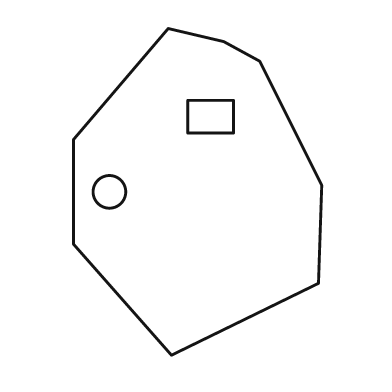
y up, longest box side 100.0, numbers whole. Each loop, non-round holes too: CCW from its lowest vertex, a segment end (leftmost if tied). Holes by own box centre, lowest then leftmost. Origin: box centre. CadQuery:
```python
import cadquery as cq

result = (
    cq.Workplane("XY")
    .moveTo(-8.0, -50.0)
    .lineTo(37.0, -28.0)
    .lineTo(38.0, 2.0)
    .lineTo(19.0, 40.0)
    .lineTo(8.0, 46.0)
    .lineTo(-9.0, 50.0)
    .lineTo(-38.0, 16.0)
    .lineTo(-38.0, -16.0)
    .close()
    .moveTo(-27.0, 0.0)
    .circle(5.0)
    .moveTo(-3.0, 18.0)
    .lineTo(11.0, 18.0)
    .lineTo(11.0, 28.0)
    .lineTo(-3.0, 28.0)
    .close()
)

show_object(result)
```